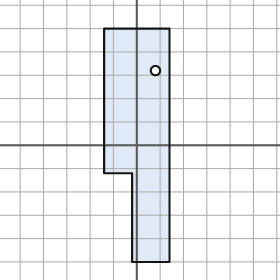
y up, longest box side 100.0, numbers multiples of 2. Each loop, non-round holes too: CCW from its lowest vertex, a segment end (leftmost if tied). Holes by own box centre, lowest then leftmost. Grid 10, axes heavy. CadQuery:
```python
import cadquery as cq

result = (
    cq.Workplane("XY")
    .moveTo(-2.0, -50.0)
    .lineTo(14.0, -50.0)
    .lineTo(14.0, 50.0)
    .lineTo(-14.0, 50.0)
    .lineTo(-14.0, -12.0)
    .lineTo(-2.0, -12.0)
    .close()
    .moveTo(8.0, 32.0)
    .circle(2.0)
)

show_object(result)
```